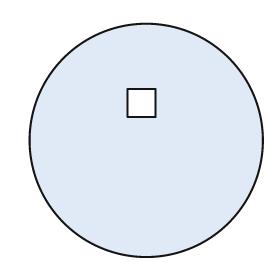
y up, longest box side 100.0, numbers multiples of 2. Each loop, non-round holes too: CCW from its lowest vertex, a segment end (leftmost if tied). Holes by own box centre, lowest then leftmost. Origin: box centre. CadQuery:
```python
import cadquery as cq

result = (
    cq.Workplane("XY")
    .moveTo(0.0, 0.0)
    .circle(50.0)
    .moveTo(-8.0, 10.0)
    .lineTo(4.0, 10.0)
    .lineTo(4.0, 22.0)
    .lineTo(-8.0, 22.0)
    .close()
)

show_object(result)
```